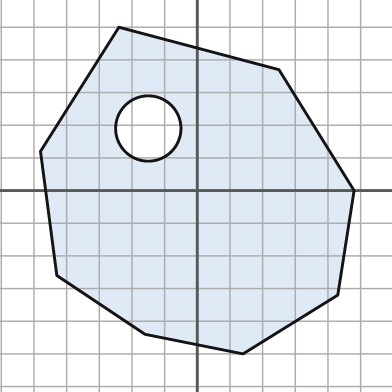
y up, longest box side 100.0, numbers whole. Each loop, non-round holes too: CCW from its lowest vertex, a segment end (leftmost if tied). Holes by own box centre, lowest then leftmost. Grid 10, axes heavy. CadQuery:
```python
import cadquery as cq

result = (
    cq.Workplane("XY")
    .moveTo(14.0, -50.0)
    .lineTo(43.0, -32.0)
    .lineTo(48.0, 0.0)
    .lineTo(25.0, 37.0)
    .lineTo(-24.0, 50.0)
    .lineTo(-48.0, 12.0)
    .lineTo(-43.0, -26.0)
    .lineTo(-16.0, -44.0)
    .close()
    .moveTo(-15.0, 19.0)
    .circle(10.0)
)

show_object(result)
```